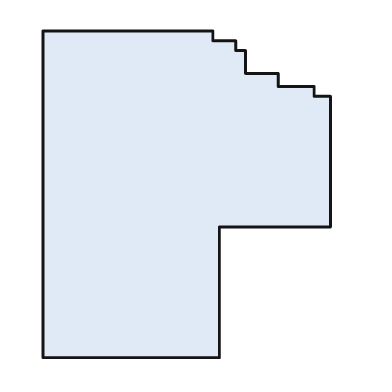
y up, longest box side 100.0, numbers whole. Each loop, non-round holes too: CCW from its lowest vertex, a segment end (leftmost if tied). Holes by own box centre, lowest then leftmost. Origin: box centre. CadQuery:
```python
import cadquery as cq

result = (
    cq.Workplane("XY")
    .moveTo(-44.0, -50.0)
    .lineTo(10.0, -50.0)
    .lineTo(10.0, -10.0)
    .lineTo(44.0, -10.0)
    .lineTo(44.0, 30.0)
    .lineTo(39.0, 30.0)
    .lineTo(39.0, 33.0)
    .lineTo(28.0, 33.0)
    .lineTo(28.0, 37.0)
    .lineTo(18.0, 37.0)
    .lineTo(18.0, 44.0)
    .lineTo(15.0, 44.0)
    .lineTo(15.0, 47.0)
    .lineTo(8.0, 47.0)
    .lineTo(8.0, 50.0)
    .lineTo(-44.0, 50.0)
    .close()
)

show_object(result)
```